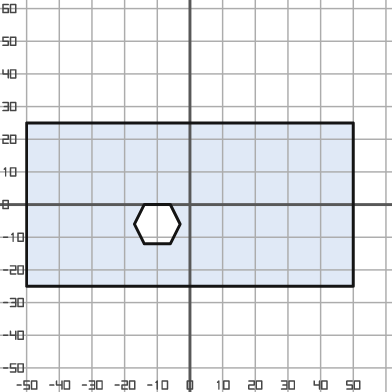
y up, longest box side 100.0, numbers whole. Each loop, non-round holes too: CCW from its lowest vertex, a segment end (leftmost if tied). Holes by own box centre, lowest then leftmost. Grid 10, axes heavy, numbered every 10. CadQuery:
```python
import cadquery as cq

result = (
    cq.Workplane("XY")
    .moveTo(-50.0, -25.0)
    .lineTo(50.0, -25.0)
    .lineTo(50.0, 25.0)
    .lineTo(-50.0, 25.0)
    .close()
    .moveTo(-14.0, -12.0)
    .lineTo(-6.0, -12.0)
    .lineTo(-3.0, -6.0)
    .lineTo(-6.0, 0.0)
    .lineTo(-14.0, 0.0)
    .lineTo(-17.0, -6.0)
    .close()
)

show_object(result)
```